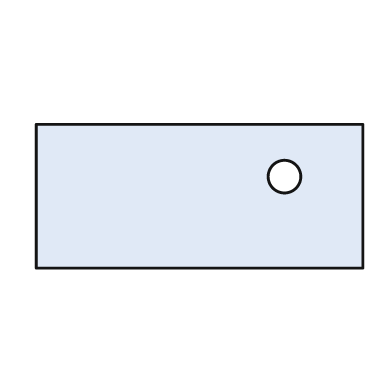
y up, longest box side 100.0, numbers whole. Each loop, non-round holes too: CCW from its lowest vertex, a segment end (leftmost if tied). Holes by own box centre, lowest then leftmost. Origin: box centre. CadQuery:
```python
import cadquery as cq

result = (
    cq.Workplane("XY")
    .moveTo(-50.0, -22.0)
    .lineTo(50.0, -22.0)
    .lineTo(50.0, 22.0)
    .lineTo(-50.0, 22.0)
    .close()
    .moveTo(26.0, 6.0)
    .circle(5.0)
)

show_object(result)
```